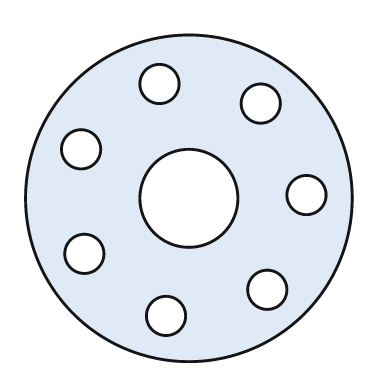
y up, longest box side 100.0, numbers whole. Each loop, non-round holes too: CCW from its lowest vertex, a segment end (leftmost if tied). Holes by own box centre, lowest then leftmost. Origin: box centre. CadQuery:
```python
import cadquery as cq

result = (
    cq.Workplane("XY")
    .moveTo(0.0, 0.0)
    .circle(50.0)
    .moveTo(-7.0, -36.0)
    .circle(6.0)
    .moveTo(24.0, -28.0)
    .circle(6.0)
    .moveTo(-32.0, -17.0)
    .circle(6.0)
    .moveTo(0.0, 0.0)
    .circle(15.0)
    .moveTo(36.0, 1.0)
    .circle(6.0)
    .moveTo(-33.0, 15.0)
    .circle(6.0)
    .moveTo(22.0, 29.0)
    .circle(6.0)
    .moveTo(-9.0, 35.0)
    .circle(6.0)
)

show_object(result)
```